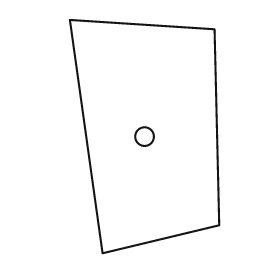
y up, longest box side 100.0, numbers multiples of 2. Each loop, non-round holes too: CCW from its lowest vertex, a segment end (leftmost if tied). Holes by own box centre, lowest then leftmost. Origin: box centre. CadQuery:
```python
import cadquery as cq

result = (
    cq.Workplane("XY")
    .moveTo(-18.0, -50.0)
    .lineTo(32.0, -38.0)
    .lineTo(30.0, 46.0)
    .lineTo(-32.0, 50.0)
    .close()
    .moveTo(0.0, 0.0)
    .circle(4.0)
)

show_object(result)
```